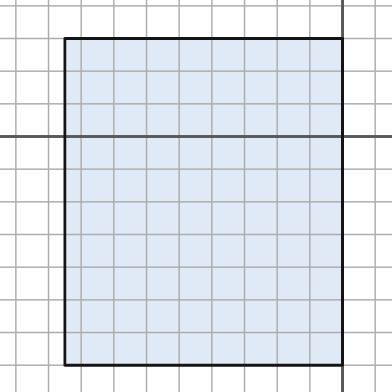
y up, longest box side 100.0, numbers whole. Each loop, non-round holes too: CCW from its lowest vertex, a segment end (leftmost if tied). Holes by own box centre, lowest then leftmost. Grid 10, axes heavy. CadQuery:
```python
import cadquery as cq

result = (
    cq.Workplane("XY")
    .moveTo(-85.0, -70.0)
    .lineTo(0.0, -70.0)
    .lineTo(0.0, 30.0)
    .lineTo(-85.0, 30.0)
    .close()
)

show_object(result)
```